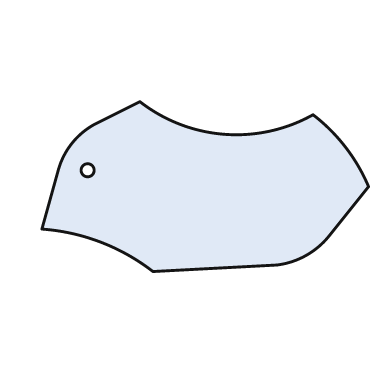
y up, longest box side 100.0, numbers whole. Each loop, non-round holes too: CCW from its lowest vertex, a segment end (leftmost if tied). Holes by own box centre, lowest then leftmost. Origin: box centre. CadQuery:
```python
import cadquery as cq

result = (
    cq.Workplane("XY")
    .moveTo(-16.0, -26.0)
    .lineTo(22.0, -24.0)
    .threePointArc((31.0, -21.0), (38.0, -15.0))
    .lineTo(50.0, 0.0)
    .threePointArc((43.0, 12.0), (33.0, 22.0))
    .threePointArc((6.0, 16.0), (-20.0, 26.0))
    .lineTo(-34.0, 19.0)
    .threePointArc((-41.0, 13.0), (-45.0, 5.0))
    .lineTo(-50.0, -13.0)
    .threePointArc((-32.0, -17.0), (-16.0, -26.0))
    .close()
    .moveTo(-36.0, 5.0)
    .circle(2.0)
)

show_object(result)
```